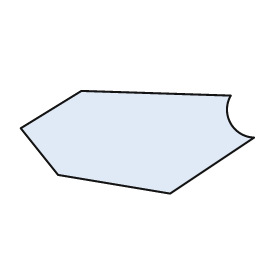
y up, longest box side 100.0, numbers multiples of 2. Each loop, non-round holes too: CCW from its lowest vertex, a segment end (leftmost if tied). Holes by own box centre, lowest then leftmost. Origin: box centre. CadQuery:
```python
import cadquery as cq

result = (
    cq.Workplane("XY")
    .moveTo(14.0, -22.0)
    .lineTo(50.0, 2.0)
    .threePointArc((40.0, 8.0), (40.0, 20.0))
    .lineTo(-24.0, 22.0)
    .lineTo(-50.0, 6.0)
    .lineTo(-34.0, -14.0)
    .close()
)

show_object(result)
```